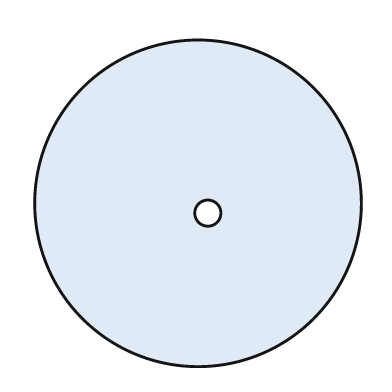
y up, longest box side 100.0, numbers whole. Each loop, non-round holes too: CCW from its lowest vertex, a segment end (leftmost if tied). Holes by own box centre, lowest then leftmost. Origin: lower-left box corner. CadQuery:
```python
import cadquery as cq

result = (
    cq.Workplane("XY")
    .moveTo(50.0, 50.0)
    .circle(50.0)
    .moveTo(53.0, 47.0)
    .circle(4.0)
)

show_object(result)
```